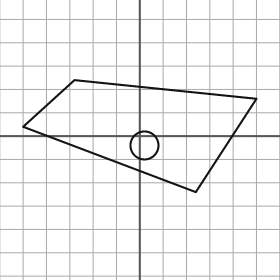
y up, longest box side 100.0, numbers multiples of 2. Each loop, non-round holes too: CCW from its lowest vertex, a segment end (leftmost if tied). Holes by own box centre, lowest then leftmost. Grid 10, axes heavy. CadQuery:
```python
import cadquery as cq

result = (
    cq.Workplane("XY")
    .moveTo(24.0, -24.0)
    .lineTo(50.0, 16.0)
    .lineTo(-28.0, 24.0)
    .lineTo(-50.0, 4.0)
    .close()
    .moveTo(2.0, -4.0)
    .circle(6.0)
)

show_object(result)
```